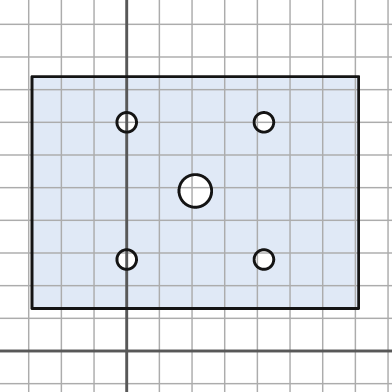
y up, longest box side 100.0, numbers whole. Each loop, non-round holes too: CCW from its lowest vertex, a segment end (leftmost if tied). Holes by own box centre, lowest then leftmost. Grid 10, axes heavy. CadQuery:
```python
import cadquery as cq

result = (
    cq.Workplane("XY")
    .moveTo(-29.0, 13.0)
    .lineTo(71.0, 13.0)
    .lineTo(71.0, 84.0)
    .lineTo(-29.0, 84.0)
    .close()
    .moveTo(0.0, 28.0)
    .circle(3.0)
    .moveTo(42.0, 28.0)
    .circle(3.0)
    .moveTo(21.0, 49.0)
    .circle(5.0)
    .moveTo(0.0, 70.0)
    .circle(3.0)
    .moveTo(42.0, 70.0)
    .circle(3.0)
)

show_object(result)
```